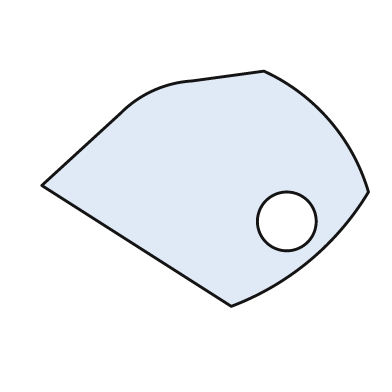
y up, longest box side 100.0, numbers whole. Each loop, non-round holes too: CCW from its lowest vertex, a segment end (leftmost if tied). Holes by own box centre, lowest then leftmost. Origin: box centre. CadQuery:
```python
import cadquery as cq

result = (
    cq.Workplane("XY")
    .moveTo(8.0, -36.0)
    .threePointArc((32.0, -22.0), (50.0, -1.0))
    .threePointArc((38.0, 21.0), (18.0, 36.0))
    .lineTo(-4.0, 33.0)
    .threePointArc((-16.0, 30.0), (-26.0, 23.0))
    .lineTo(-50.0, 1.0)
    .close()
    .moveTo(25.0, -10.0)
    .circle(9.0)
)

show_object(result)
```